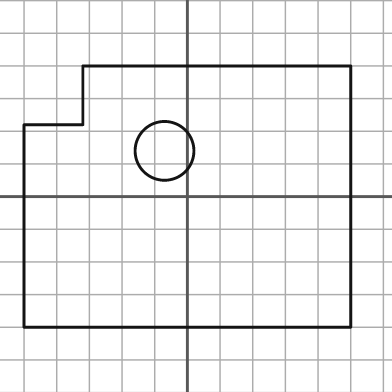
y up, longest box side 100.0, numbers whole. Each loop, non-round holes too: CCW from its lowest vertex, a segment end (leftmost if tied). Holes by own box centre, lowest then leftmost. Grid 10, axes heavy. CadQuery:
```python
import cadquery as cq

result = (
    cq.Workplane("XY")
    .moveTo(-50.0, -40.0)
    .lineTo(50.0, -40.0)
    .lineTo(50.0, 40.0)
    .lineTo(-32.0, 40.0)
    .lineTo(-32.0, 22.0)
    .lineTo(-50.0, 22.0)
    .close()
    .moveTo(-7.0, 14.0)
    .circle(9.0)
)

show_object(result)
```